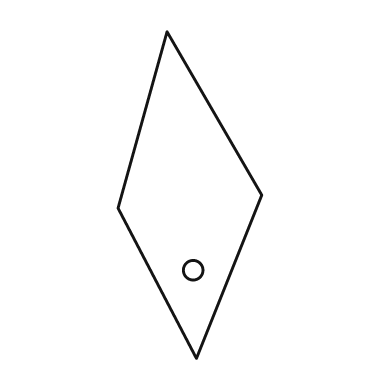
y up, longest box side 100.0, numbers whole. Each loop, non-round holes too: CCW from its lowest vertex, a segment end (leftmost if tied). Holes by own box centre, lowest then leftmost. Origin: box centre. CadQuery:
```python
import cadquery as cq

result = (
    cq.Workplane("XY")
    .moveTo(2.0, -50.0)
    .lineTo(22.0, 0.0)
    .lineTo(-7.0, 50.0)
    .lineTo(-22.0, -4.0)
    .close()
    .moveTo(1.0, -23.0)
    .circle(3.0)
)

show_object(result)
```